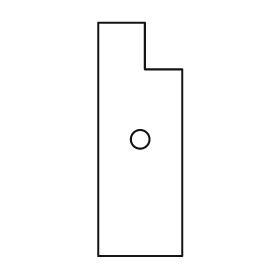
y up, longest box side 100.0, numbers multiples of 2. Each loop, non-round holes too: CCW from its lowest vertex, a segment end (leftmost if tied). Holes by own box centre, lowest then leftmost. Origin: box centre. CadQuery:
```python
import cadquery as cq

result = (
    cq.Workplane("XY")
    .moveTo(-18.0, -50.0)
    .lineTo(18.0, -50.0)
    .lineTo(18.0, 30.0)
    .lineTo(2.0, 30.0)
    .lineTo(2.0, 50.0)
    .lineTo(-18.0, 50.0)
    .close()
    .moveTo(0.0, 0.0)
    .circle(4.0)
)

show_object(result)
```